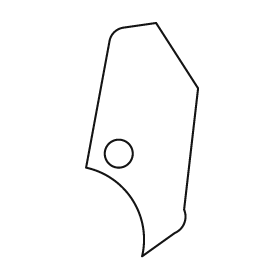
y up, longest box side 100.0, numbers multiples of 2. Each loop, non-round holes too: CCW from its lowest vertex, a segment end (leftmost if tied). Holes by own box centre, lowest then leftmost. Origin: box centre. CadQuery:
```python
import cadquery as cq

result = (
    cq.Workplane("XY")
    .moveTo(0.0, -50.0)
    .lineTo(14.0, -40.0)
    .threePointArc((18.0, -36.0), (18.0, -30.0))
    .lineTo(24.0, 22.0)
    .lineTo(6.0, 50.0)
    .lineTo(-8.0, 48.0)
    .threePointArc((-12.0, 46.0), (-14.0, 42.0))
    .lineTo(-24.0, -12.0)
    .threePointArc((-4.0, -26.0), (0.0, -50.0))
    .close()
    .moveTo(-10.0, -6.0)
    .circle(6.0)
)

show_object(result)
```